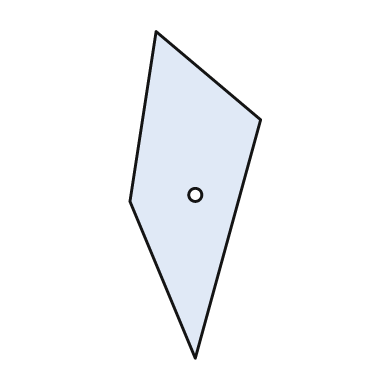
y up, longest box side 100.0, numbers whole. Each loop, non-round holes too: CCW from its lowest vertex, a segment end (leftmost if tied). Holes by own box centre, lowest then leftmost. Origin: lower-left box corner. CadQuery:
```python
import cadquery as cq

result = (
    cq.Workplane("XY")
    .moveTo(20.0, 0.0)
    .lineTo(40.0, 73.0)
    .lineTo(8.0, 100.0)
    .lineTo(0.0, 48.0)
    .close()
    .moveTo(20.0, 50.0)
    .circle(2.0)
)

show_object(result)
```